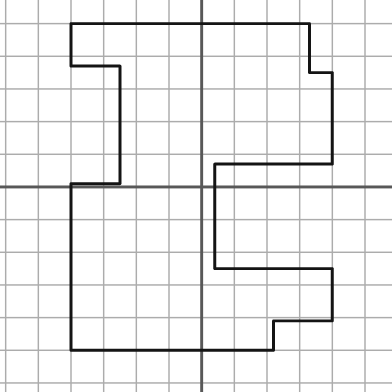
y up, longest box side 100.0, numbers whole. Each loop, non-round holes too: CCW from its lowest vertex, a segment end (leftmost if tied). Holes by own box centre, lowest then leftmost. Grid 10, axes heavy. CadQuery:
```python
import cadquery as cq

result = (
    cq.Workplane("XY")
    .moveTo(-40.0, -50.0)
    .lineTo(22.0, -50.0)
    .lineTo(22.0, -41.0)
    .lineTo(40.0, -41.0)
    .lineTo(40.0, -25.0)
    .lineTo(4.0, -25.0)
    .lineTo(4.0, 7.0)
    .lineTo(40.0, 7.0)
    .lineTo(40.0, 35.0)
    .lineTo(33.0, 35.0)
    .lineTo(33.0, 50.0)
    .lineTo(-40.0, 50.0)
    .lineTo(-40.0, 37.0)
    .lineTo(-25.0, 37.0)
    .lineTo(-25.0, 1.0)
    .lineTo(-40.0, 1.0)
    .close()
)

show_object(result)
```